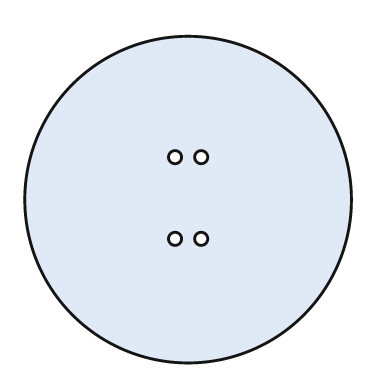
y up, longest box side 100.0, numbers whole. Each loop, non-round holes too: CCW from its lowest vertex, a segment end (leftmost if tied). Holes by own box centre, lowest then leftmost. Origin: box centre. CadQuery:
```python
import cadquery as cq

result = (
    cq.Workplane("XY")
    .moveTo(0.0, 0.0)
    .circle(50.0)
    .moveTo(-4.0, -12.0)
    .circle(2.0)
    .moveTo(4.0, -12.0)
    .circle(2.0)
    .moveTo(-4.0, 13.0)
    .circle(2.0)
    .moveTo(4.0, 13.0)
    .circle(2.0)
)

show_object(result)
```